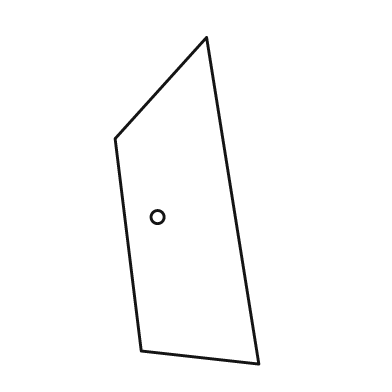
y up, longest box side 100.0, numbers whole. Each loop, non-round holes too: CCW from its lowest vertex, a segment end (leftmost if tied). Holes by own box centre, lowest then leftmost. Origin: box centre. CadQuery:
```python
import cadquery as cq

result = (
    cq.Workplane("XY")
    .moveTo(22.0, -50.0)
    .lineTo(6.0, 50.0)
    .lineTo(-22.0, 19.0)
    .lineTo(-14.0, -46.0)
    .close()
    .moveTo(-9.0, -5.0)
    .circle(2.0)
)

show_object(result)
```